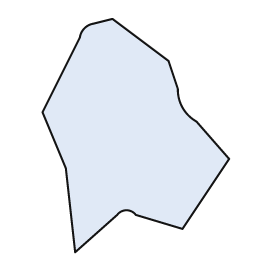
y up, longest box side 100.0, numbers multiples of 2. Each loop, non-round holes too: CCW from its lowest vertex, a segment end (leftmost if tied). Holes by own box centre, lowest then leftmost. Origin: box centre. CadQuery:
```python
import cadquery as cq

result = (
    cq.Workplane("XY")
    .moveTo(-26.0, -50.0)
    .lineTo(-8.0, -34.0)
    .threePointArc((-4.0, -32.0), (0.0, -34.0))
    .lineTo(20.0, -40.0)
    .lineTo(40.0, -10.0)
    .lineTo(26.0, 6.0)
    .threePointArc((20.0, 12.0), (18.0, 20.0))
    .lineTo(14.0, 32.0)
    .lineTo(-10.0, 50.0)
    .lineTo(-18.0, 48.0)
    .threePointArc((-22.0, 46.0), (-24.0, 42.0))
    .lineTo(-40.0, 10.0)
    .lineTo(-30.0, -14.0)
    .close()
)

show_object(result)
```